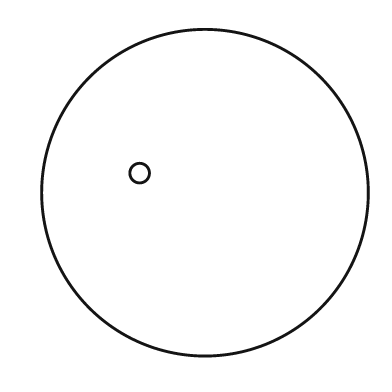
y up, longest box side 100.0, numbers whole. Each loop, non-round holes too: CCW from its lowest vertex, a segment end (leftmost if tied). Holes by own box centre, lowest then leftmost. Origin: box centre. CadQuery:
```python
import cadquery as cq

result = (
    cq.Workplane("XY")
    .moveTo(0.0, 0.0)
    .circle(50.0)
    .moveTo(-20.0, 6.0)
    .circle(3.0)
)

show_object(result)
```